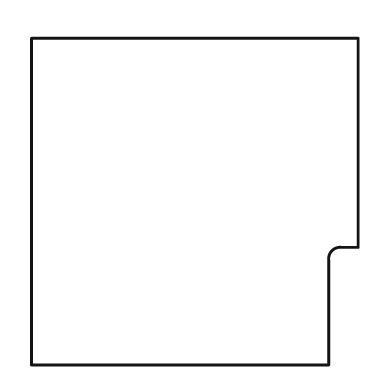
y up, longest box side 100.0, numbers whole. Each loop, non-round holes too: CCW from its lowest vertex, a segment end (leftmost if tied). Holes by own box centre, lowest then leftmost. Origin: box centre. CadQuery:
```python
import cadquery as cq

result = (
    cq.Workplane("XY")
    .moveTo(-50.0, -50.0)
    .lineTo(41.0, -50.0)
    .lineTo(41.0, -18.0)
    .threePointArc((42.0, -15.0), (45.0, -14.0))
    .lineTo(50.0, -14.0)
    .lineTo(50.0, 50.0)
    .lineTo(-50.0, 50.0)
    .close()
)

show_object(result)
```